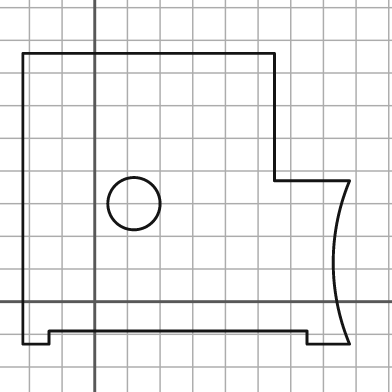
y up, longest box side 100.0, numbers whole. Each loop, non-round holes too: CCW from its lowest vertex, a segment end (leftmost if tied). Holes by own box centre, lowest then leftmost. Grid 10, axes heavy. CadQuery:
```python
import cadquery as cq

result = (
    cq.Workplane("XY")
    .moveTo(-22.0, -13.0)
    .lineTo(-14.0, -13.0)
    .lineTo(-14.0, -9.0)
    .lineTo(65.0, -9.0)
    .lineTo(65.0, -13.0)
    .lineTo(78.0, -13.0)
    .threePointArc((73.0, 12.0), (78.0, 37.0))
    .lineTo(55.0, 37.0)
    .lineTo(55.0, 76.0)
    .lineTo(-22.0, 76.0)
    .close()
    .moveTo(12.0, 30.0)
    .circle(8.0)
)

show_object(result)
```